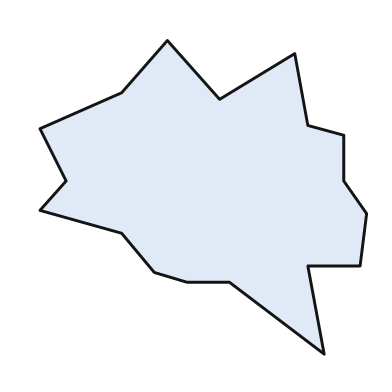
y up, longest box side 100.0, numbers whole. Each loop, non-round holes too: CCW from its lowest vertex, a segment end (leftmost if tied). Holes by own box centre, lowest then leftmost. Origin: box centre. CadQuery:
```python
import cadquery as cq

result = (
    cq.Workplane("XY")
    .moveTo(37.0, -48.0)
    .lineTo(32.0, -21.0)
    .lineTo(48.0, -21.0)
    .lineTo(50.0, -5.0)
    .lineTo(43.0, 5.0)
    .lineTo(43.0, 19.0)
    .lineTo(32.0, 22.0)
    .lineTo(28.0, 44.0)
    .lineTo(5.0, 30.0)
    .lineTo(-11.0, 48.0)
    .lineTo(-25.0, 32.0)
    .lineTo(-50.0, 21.0)
    .lineTo(-42.0, 5.0)
    .lineTo(-50.0, -4.0)
    .lineTo(-25.0, -11.0)
    .lineTo(-15.0, -23.0)
    .lineTo(-5.0, -26.0)
    .lineTo(8.0, -26.0)
    .close()
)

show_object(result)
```